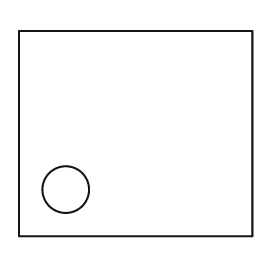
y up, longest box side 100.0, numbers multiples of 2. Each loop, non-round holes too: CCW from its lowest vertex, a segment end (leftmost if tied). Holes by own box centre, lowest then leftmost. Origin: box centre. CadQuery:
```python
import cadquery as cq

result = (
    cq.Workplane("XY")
    .moveTo(-50.0, -44.0)
    .lineTo(50.0, -44.0)
    .lineTo(50.0, 44.0)
    .lineTo(-50.0, 44.0)
    .close()
    .moveTo(-30.0, -24.0)
    .circle(10.0)
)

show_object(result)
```